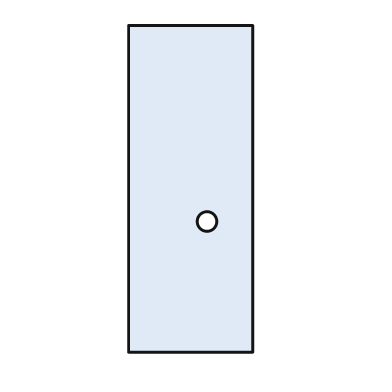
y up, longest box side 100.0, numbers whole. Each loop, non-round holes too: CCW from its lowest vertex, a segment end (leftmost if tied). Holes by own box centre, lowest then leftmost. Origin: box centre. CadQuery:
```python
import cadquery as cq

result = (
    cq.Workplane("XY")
    .moveTo(-19.0, -50.0)
    .lineTo(19.0, -50.0)
    .lineTo(19.0, 50.0)
    .lineTo(-19.0, 50.0)
    .close()
    .moveTo(5.0, -10.0)
    .circle(3.0)
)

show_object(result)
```